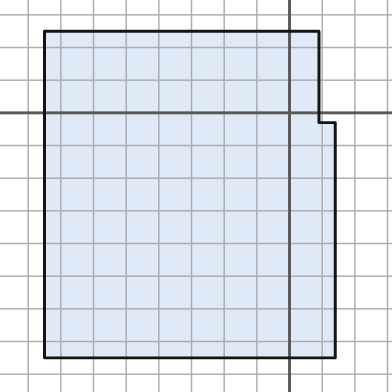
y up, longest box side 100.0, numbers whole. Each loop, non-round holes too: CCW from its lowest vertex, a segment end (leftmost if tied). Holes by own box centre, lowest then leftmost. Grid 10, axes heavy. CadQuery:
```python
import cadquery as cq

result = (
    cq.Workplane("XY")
    .moveTo(-75.0, -75.0)
    .lineTo(14.0, -75.0)
    .lineTo(14.0, -3.0)
    .lineTo(9.0, -3.0)
    .lineTo(9.0, 25.0)
    .lineTo(-75.0, 25.0)
    .close()
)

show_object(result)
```